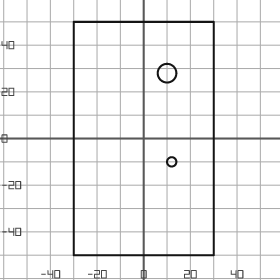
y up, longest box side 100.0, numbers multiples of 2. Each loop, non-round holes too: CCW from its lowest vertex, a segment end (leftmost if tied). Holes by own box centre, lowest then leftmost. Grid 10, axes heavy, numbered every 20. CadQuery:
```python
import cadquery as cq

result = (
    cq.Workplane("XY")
    .moveTo(-30.0, -50.0)
    .lineTo(30.0, -50.0)
    .lineTo(30.0, 50.0)
    .lineTo(-30.0, 50.0)
    .close()
    .moveTo(12.0, -10.0)
    .circle(2.0)
    .moveTo(10.0, 28.0)
    .circle(4.0)
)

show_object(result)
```